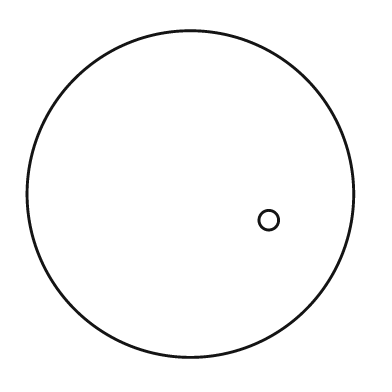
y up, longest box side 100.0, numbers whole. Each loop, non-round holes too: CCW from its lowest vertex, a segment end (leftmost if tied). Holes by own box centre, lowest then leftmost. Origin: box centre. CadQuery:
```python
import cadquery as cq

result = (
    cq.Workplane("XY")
    .moveTo(0.0, 0.0)
    .circle(50.0)
    .moveTo(24.0, -8.0)
    .circle(3.0)
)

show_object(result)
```